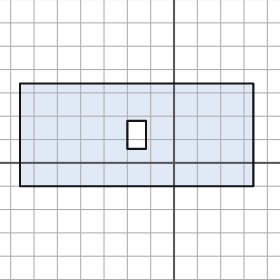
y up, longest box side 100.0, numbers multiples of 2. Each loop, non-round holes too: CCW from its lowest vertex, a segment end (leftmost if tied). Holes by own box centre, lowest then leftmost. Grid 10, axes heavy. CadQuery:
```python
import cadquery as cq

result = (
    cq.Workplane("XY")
    .moveTo(-66.0, -10.0)
    .lineTo(34.0, -10.0)
    .lineTo(34.0, 34.0)
    .lineTo(-66.0, 34.0)
    .close()
    .moveTo(-20.0, 6.0)
    .lineTo(-12.0, 6.0)
    .lineTo(-12.0, 18.0)
    .lineTo(-20.0, 18.0)
    .close()
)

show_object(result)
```